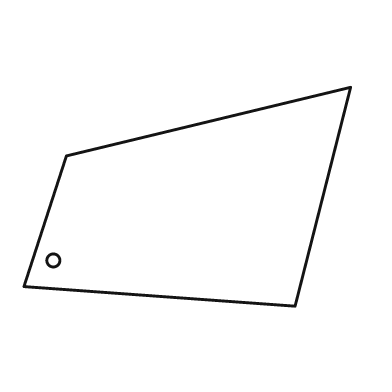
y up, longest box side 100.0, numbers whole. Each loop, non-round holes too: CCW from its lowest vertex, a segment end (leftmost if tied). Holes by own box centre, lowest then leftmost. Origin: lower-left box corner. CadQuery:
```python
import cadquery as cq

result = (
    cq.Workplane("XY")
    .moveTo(83.0, 0.0)
    .lineTo(100.0, 67.0)
    .lineTo(13.0, 46.0)
    .lineTo(0.0, 6.0)
    .close()
    .moveTo(9.0, 14.0)
    .circle(2.0)
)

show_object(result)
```